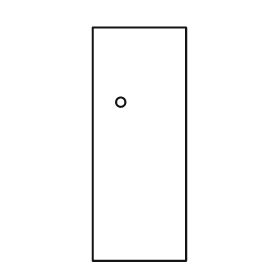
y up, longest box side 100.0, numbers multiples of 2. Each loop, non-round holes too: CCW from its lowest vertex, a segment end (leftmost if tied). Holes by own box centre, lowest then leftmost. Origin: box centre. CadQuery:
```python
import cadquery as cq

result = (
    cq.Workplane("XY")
    .moveTo(-20.0, -50.0)
    .lineTo(20.0, -50.0)
    .lineTo(20.0, 50.0)
    .lineTo(-20.0, 50.0)
    .close()
    .moveTo(-8.0, 18.0)
    .circle(2.0)
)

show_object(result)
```